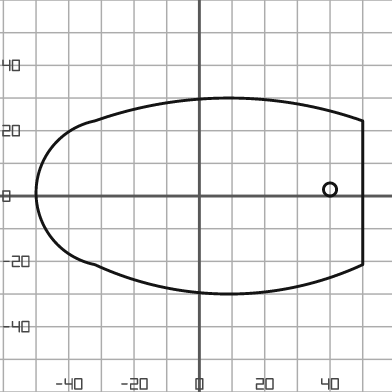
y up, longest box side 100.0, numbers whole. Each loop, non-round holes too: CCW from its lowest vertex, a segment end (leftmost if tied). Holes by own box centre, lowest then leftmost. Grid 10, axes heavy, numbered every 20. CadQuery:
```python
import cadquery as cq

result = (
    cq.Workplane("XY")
    .moveTo(-32.0, -21.0)
    .threePointArc((9.0, -30.0), (50.0, -21.0))
    .lineTo(50.0, 23.0)
    .threePointArc((9.0, 30.0), (-32.0, 23.0))
    .threePointArc((-50.0, 1.0), (-32.0, -21.0))
    .close()
    .moveTo(40.0, 2.0)
    .circle(2.0)
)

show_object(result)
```